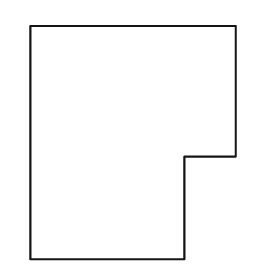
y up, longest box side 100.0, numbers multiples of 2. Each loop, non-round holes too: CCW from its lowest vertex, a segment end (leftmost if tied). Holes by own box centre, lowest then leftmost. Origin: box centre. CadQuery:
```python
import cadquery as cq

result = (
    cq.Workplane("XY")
    .moveTo(-44.0, -50.0)
    .lineTo(22.0, -50.0)
    .lineTo(22.0, -6.0)
    .lineTo(44.0, -6.0)
    .lineTo(44.0, 50.0)
    .lineTo(-44.0, 50.0)
    .close()
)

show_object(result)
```